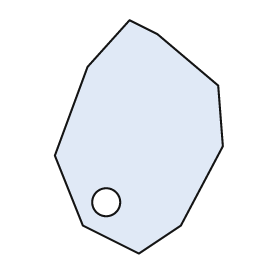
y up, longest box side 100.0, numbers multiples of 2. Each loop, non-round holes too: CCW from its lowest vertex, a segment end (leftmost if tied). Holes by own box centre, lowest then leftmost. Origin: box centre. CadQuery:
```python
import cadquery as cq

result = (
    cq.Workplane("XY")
    .moveTo(0.0, -50.0)
    .lineTo(18.0, -38.0)
    .lineTo(36.0, -4.0)
    .lineTo(34.0, 22.0)
    .lineTo(8.0, 44.0)
    .lineTo(-4.0, 50.0)
    .lineTo(-22.0, 30.0)
    .lineTo(-36.0, -8.0)
    .lineTo(-24.0, -38.0)
    .close()
    .moveTo(-14.0, -28.0)
    .circle(6.0)
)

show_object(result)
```